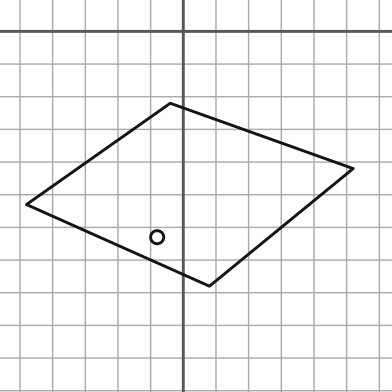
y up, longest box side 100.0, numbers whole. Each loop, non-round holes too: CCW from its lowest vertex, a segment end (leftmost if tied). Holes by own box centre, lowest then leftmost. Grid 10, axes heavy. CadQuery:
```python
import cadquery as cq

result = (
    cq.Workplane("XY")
    .moveTo(8.0, -78.0)
    .lineTo(52.0, -42.0)
    .lineTo(-4.0, -22.0)
    .lineTo(-48.0, -53.0)
    .close()
    .moveTo(-8.0, -63.0)
    .circle(2.0)
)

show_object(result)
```